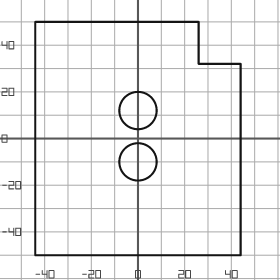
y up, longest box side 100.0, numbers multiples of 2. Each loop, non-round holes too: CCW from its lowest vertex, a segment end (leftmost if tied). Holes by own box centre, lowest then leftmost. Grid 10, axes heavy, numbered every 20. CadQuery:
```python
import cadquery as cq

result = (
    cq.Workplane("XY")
    .moveTo(-44.0, -50.0)
    .lineTo(44.0, -50.0)
    .lineTo(44.0, 32.0)
    .lineTo(26.0, 32.0)
    .lineTo(26.0, 50.0)
    .lineTo(-44.0, 50.0)
    .close()
    .moveTo(0.0, -10.0)
    .circle(8.0)
    .moveTo(0.0, 12.0)
    .circle(8.0)
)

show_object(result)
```